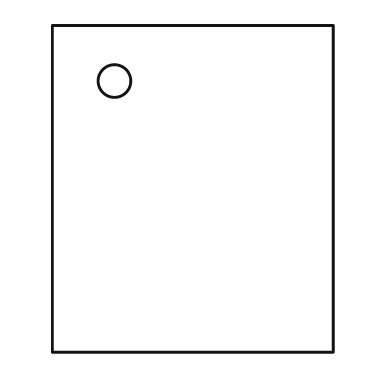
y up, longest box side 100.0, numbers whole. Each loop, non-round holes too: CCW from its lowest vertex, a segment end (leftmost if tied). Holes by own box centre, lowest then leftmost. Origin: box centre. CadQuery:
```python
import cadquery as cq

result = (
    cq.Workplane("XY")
    .moveTo(-43.0, -50.0)
    .lineTo(43.0, -50.0)
    .lineTo(43.0, 50.0)
    .lineTo(-43.0, 50.0)
    .close()
    .moveTo(-24.0, 33.0)
    .circle(5.0)
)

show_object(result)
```